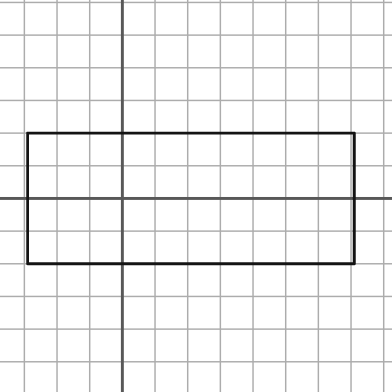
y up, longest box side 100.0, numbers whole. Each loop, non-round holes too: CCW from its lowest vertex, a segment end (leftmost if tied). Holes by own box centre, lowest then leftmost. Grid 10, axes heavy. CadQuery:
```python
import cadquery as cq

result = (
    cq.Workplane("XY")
    .moveTo(-29.0, -20.0)
    .lineTo(71.0, -20.0)
    .lineTo(71.0, 20.0)
    .lineTo(-29.0, 20.0)
    .close()
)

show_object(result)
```